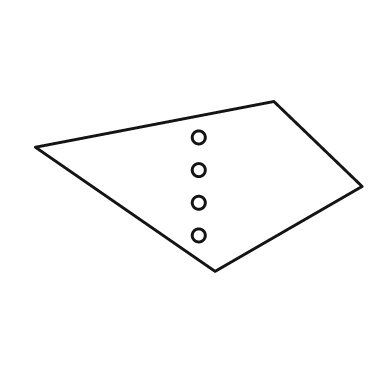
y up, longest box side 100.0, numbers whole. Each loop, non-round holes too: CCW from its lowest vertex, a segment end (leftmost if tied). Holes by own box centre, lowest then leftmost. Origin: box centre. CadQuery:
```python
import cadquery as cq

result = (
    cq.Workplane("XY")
    .moveTo(5.0, -26.0)
    .lineTo(50.0, 0.0)
    .lineTo(23.0, 26.0)
    .lineTo(-50.0, 12.0)
    .close()
    .moveTo(0.0, -15.0)
    .circle(2.0)
    .moveTo(0.0, -5.0)
    .circle(2.0)
    .moveTo(0.0, 5.0)
    .circle(2.0)
    .moveTo(0.0, 15.0)
    .circle(2.0)
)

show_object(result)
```